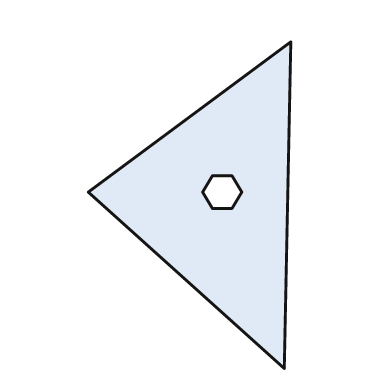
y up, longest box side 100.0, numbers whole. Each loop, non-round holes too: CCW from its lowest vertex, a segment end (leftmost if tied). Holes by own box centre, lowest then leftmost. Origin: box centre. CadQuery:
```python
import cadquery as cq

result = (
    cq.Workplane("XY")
    .moveTo(29.0, -50.0)
    .lineTo(31.0, 50.0)
    .lineTo(-31.0, 4.0)
    .close()
    .moveTo(7.0, -1.0)
    .lineTo(13.0, -1.0)
    .lineTo(16.0, 4.0)
    .lineTo(13.0, 9.0)
    .lineTo(7.0, 9.0)
    .lineTo(4.0, 4.0)
    .close()
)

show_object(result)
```